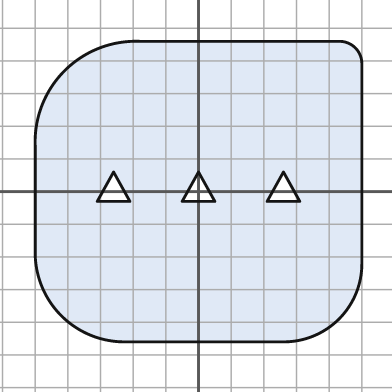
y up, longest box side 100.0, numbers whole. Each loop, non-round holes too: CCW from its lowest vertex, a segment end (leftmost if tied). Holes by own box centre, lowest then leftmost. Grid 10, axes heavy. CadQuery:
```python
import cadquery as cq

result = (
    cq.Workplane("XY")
    .moveTo(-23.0, -46.0)
    .lineTo(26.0, -46.0)
    .threePointArc((43.0, -39.0), (50.0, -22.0))
    .lineTo(50.0, 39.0)
    .threePointArc((48.0, 44.0), (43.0, 46.0))
    .lineTo(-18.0, 46.0)
    .threePointArc((-41.0, 37.0), (-50.0, 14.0))
    .lineTo(-50.0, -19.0)
    .threePointArc((-42.0, -38.0), (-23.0, -46.0))
    .close()
    .moveTo(-31.0, -3.0)
    .lineTo(-21.0, -3.0)
    .lineTo(-26.0, 6.0)
    .close()
    .moveTo(-5.0, -3.0)
    .lineTo(5.0, -3.0)
    .lineTo(0.0, 6.0)
    .close()
    .moveTo(21.0, -3.0)
    .lineTo(31.0, -3.0)
    .lineTo(26.0, 6.0)
    .close()
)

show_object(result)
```